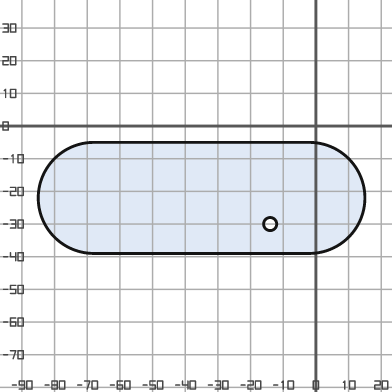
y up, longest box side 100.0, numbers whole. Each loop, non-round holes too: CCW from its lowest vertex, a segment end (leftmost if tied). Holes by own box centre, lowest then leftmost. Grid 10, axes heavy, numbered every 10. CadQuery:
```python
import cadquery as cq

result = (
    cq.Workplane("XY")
    .moveTo(-68.0, -39.0)
    .lineTo(-2.0, -39.0)
    .threePointArc((15.0, -22.0), (-2.0, -5.0))
    .lineTo(-68.0, -5.0)
    .threePointArc((-85.0, -22.0), (-68.0, -39.0))
    .close()
    .moveTo(-14.0, -30.0)
    .circle(2.0)
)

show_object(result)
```